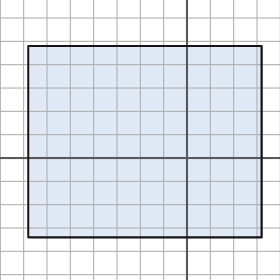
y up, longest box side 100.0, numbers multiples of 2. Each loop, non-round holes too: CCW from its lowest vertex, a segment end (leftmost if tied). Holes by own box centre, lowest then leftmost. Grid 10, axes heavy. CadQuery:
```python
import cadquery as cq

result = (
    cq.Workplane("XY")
    .moveTo(-68.0, -34.0)
    .lineTo(32.0, -34.0)
    .lineTo(32.0, 48.0)
    .lineTo(-68.0, 48.0)
    .close()
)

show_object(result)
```